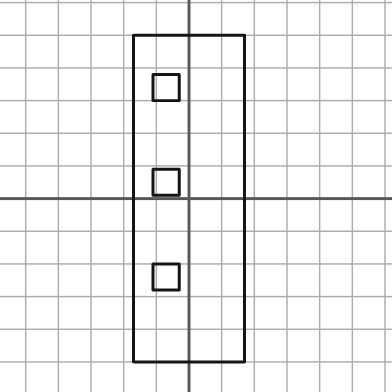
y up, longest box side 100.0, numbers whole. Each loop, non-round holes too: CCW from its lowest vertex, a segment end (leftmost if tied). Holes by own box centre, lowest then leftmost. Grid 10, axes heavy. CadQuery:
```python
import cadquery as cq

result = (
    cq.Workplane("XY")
    .moveTo(-17.0, -50.0)
    .lineTo(17.0, -50.0)
    .lineTo(17.0, 50.0)
    .lineTo(-17.0, 50.0)
    .close()
    .moveTo(-11.0, -28.0)
    .lineTo(-3.0, -28.0)
    .lineTo(-3.0, -20.0)
    .lineTo(-11.0, -20.0)
    .close()
    .moveTo(-11.0, 1.0)
    .lineTo(-3.0, 1.0)
    .lineTo(-3.0, 9.0)
    .lineTo(-11.0, 9.0)
    .close()
    .moveTo(-11.0, 30.0)
    .lineTo(-3.0, 30.0)
    .lineTo(-3.0, 38.0)
    .lineTo(-11.0, 38.0)
    .close()
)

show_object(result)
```